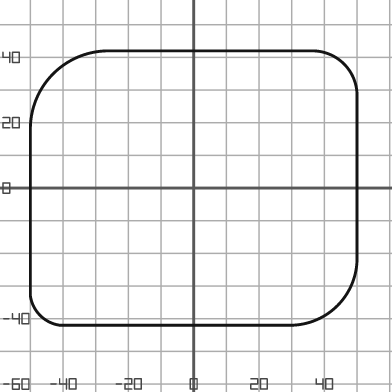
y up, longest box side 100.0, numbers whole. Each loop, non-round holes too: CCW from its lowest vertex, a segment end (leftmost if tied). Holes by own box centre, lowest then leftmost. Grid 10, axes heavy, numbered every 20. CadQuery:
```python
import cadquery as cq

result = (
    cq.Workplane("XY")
    .moveTo(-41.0, -42.0)
    .lineTo(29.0, -42.0)
    .threePointArc((44.0, -36.0), (50.0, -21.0))
    .lineTo(50.0, 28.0)
    .threePointArc((46.0, 38.0), (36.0, 42.0))
    .lineTo(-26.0, 42.0)
    .threePointArc((-43.0, 35.0), (-50.0, 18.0))
    .lineTo(-50.0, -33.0)
    .threePointArc((-47.0, -39.0), (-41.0, -42.0))
    .close()
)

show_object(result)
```